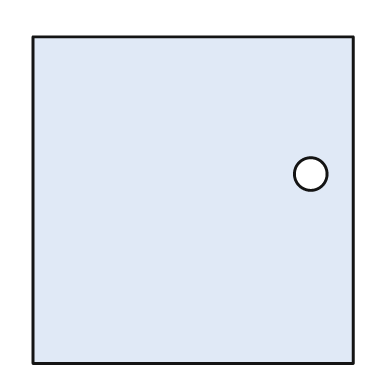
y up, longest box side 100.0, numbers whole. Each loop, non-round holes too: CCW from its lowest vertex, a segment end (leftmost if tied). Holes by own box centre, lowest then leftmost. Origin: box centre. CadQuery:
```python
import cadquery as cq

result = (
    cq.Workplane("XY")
    .moveTo(-49.0, -50.0)
    .lineTo(49.0, -50.0)
    .lineTo(49.0, 50.0)
    .lineTo(-49.0, 50.0)
    .close()
    .moveTo(36.0, 8.0)
    .circle(5.0)
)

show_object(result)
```